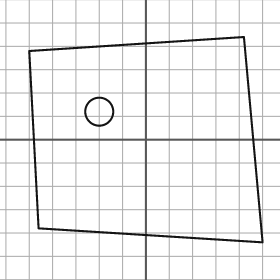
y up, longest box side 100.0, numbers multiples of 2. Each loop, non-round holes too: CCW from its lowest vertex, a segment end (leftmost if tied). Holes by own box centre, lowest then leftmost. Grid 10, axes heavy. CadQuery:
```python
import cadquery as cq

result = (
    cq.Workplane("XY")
    .moveTo(50.0, -44.0)
    .lineTo(42.0, 44.0)
    .lineTo(-50.0, 38.0)
    .lineTo(-46.0, -38.0)
    .close()
    .moveTo(-20.0, 12.0)
    .circle(6.0)
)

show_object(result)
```